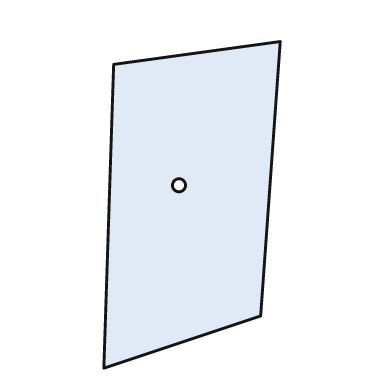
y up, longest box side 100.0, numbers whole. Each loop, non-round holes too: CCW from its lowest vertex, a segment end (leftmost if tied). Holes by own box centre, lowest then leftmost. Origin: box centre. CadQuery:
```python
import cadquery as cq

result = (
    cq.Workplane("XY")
    .moveTo(-27.0, -50.0)
    .lineTo(21.0, -34.0)
    .lineTo(27.0, 50.0)
    .lineTo(-24.0, 43.0)
    .close()
    .moveTo(-4.0, 6.0)
    .circle(2.0)
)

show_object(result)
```